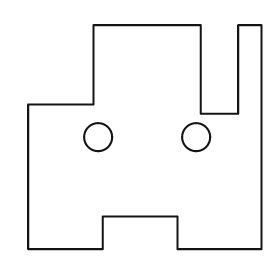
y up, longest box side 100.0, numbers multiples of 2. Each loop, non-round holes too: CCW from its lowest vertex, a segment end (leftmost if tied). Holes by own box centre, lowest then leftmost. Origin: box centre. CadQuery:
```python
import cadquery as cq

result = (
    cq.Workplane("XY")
    .moveTo(-50.0, -48.0)
    .lineTo(-18.0, -48.0)
    .lineTo(-18.0, -34.0)
    .lineTo(14.0, -34.0)
    .lineTo(14.0, -48.0)
    .lineTo(50.0, -48.0)
    .lineTo(50.0, 48.0)
    .lineTo(40.0, 48.0)
    .lineTo(40.0, 10.0)
    .lineTo(24.0, 10.0)
    .lineTo(24.0, 48.0)
    .lineTo(-22.0, 48.0)
    .lineTo(-22.0, 14.0)
    .lineTo(-50.0, 14.0)
    .close()
    .moveTo(-20.0, 0.0)
    .circle(6.0)
    .moveTo(22.0, 0.0)
    .circle(6.0)
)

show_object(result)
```